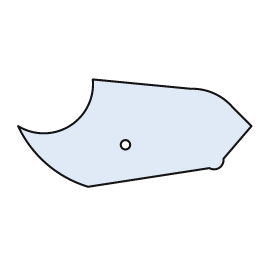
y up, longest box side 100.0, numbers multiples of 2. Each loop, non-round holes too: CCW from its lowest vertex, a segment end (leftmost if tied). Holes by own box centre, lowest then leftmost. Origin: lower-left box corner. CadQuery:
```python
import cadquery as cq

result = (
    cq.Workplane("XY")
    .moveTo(30.0, 0.0)
    .lineTo(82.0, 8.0)
    .threePointArc((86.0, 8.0), (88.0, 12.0))
    .lineTo(100.0, 26.0)
    .lineTo(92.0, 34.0)
    .threePointArc((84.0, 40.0), (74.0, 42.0))
    .lineTo(32.0, 46.0)
    .threePointArc((22.0, 26.0), (0.0, 26.0))
    .threePointArc((12.0, 10.0), (30.0, 0.0))
    .close()
    .moveTo(46.0, 18.0)
    .circle(2.0)
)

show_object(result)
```